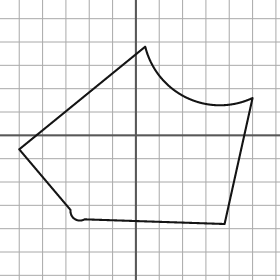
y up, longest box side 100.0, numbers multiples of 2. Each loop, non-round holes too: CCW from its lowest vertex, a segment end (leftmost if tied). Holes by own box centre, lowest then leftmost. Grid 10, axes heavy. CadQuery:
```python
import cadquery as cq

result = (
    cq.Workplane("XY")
    .moveTo(38.0, -38.0)
    .lineTo(50.0, 16.0)
    .threePointArc((22.0, 16.0), (4.0, 38.0))
    .lineTo(-50.0, -6.0)
    .lineTo(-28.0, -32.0)
    .threePointArc((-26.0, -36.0), (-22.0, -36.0))
    .close()
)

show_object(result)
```